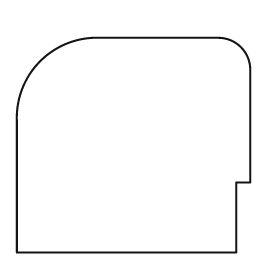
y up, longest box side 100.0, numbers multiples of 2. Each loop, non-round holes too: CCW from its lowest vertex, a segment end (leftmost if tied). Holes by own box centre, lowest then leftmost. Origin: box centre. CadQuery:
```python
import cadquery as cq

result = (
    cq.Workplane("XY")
    .moveTo(-50.0, -46.0)
    .lineTo(44.0, -46.0)
    .lineTo(44.0, -16.0)
    .lineTo(50.0, -16.0)
    .lineTo(50.0, 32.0)
    .threePointArc((46.0, 42.0), (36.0, 46.0))
    .lineTo(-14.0, 46.0)
    .threePointArc((-40.0, 36.0), (-50.0, 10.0))
    .close()
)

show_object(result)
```